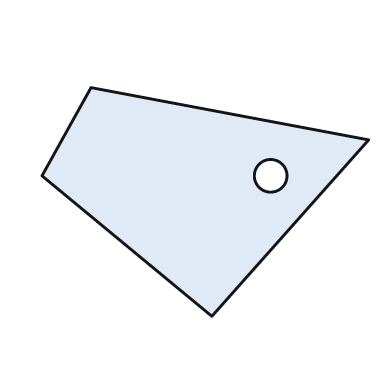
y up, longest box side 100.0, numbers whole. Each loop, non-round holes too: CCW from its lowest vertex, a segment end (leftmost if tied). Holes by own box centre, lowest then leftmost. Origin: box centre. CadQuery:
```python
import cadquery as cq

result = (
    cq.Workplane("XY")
    .moveTo(2.0, -35.0)
    .lineTo(50.0, 19.0)
    .lineTo(-35.0, 35.0)
    .lineTo(-50.0, 8.0)
    .close()
    .moveTo(20.0, 8.0)
    .circle(5.0)
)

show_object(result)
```